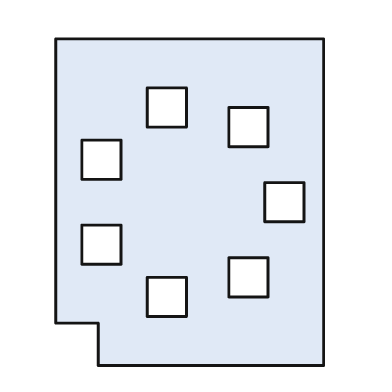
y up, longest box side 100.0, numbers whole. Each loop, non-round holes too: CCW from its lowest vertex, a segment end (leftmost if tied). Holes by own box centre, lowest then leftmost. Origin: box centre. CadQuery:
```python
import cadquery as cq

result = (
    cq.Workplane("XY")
    .moveTo(-28.0, -50.0)
    .lineTo(41.0, -50.0)
    .lineTo(41.0, 50.0)
    .lineTo(-41.0, 50.0)
    .lineTo(-41.0, -37.0)
    .lineTo(-28.0, -37.0)
    .close()
    .moveTo(-13.0, -35.0)
    .lineTo(-1.0, -35.0)
    .lineTo(-1.0, -23.0)
    .lineTo(-13.0, -23.0)
    .close()
    .moveTo(12.0, -29.0)
    .lineTo(24.0, -29.0)
    .lineTo(24.0, -17.0)
    .lineTo(12.0, -17.0)
    .close()
    .moveTo(-33.0, -19.0)
    .lineTo(-21.0, -19.0)
    .lineTo(-21.0, -7.0)
    .lineTo(-33.0, -7.0)
    .close()
    .moveTo(23.0, -6.0)
    .lineTo(35.0, -6.0)
    .lineTo(35.0, 6.0)
    .lineTo(23.0, 6.0)
    .close()
    .moveTo(-33.0, 7.0)
    .lineTo(-21.0, 7.0)
    .lineTo(-21.0, 19.0)
    .lineTo(-33.0, 19.0)
    .close()
    .moveTo(12.0, 17.0)
    .lineTo(24.0, 17.0)
    .lineTo(24.0, 29.0)
    .lineTo(12.0, 29.0)
    .close()
    .moveTo(-13.0, 23.0)
    .lineTo(-1.0, 23.0)
    .lineTo(-1.0, 35.0)
    .lineTo(-13.0, 35.0)
    .close()
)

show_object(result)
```